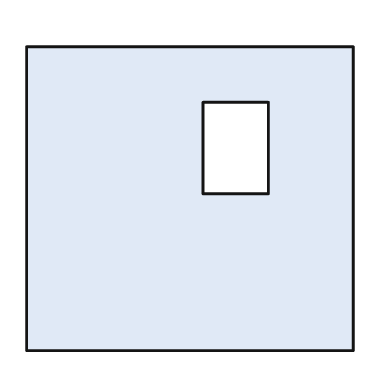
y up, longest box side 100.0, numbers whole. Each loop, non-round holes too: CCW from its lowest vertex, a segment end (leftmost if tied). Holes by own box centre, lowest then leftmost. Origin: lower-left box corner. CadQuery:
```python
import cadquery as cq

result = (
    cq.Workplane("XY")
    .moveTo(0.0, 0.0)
    .lineTo(100.0, 0.0)
    .lineTo(100.0, 93.0)
    .lineTo(0.0, 93.0)
    .close()
    .moveTo(54.0, 48.0)
    .lineTo(74.0, 48.0)
    .lineTo(74.0, 76.0)
    .lineTo(54.0, 76.0)
    .close()
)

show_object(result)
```